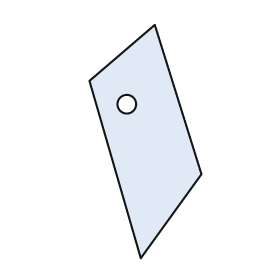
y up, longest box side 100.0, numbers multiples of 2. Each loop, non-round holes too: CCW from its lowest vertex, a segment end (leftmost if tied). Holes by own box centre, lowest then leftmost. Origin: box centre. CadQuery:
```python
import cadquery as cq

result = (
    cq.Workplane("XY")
    .moveTo(-2.0, -50.0)
    .lineTo(24.0, -14.0)
    .lineTo(4.0, 50.0)
    .lineTo(-24.0, 26.0)
    .close()
    .moveTo(-8.0, 16.0)
    .circle(4.0)
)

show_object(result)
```